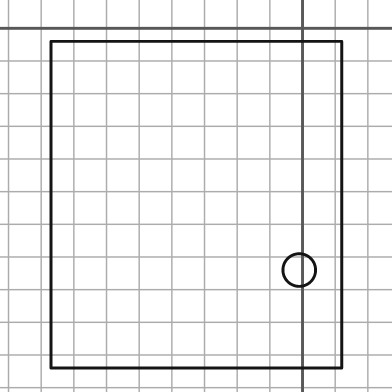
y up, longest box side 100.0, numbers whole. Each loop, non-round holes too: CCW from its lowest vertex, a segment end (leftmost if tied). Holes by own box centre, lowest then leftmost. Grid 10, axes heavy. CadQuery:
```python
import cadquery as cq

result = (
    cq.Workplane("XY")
    .moveTo(-77.0, -104.0)
    .lineTo(12.0, -104.0)
    .lineTo(12.0, -4.0)
    .lineTo(-77.0, -4.0)
    .close()
    .moveTo(-1.0, -74.0)
    .circle(5.0)
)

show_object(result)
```